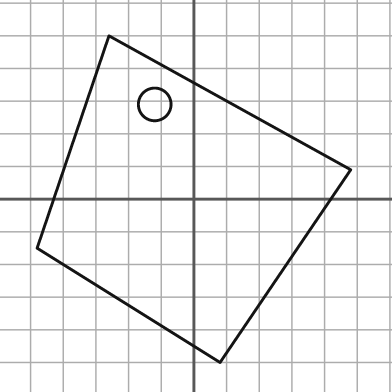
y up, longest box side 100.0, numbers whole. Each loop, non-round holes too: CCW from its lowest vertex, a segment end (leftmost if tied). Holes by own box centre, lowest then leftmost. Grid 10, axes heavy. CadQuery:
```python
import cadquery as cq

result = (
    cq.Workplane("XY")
    .moveTo(8.0, -50.0)
    .lineTo(48.0, 9.0)
    .lineTo(-26.0, 50.0)
    .lineTo(-48.0, -15.0)
    .close()
    .moveTo(-12.0, 29.0)
    .circle(5.0)
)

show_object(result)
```